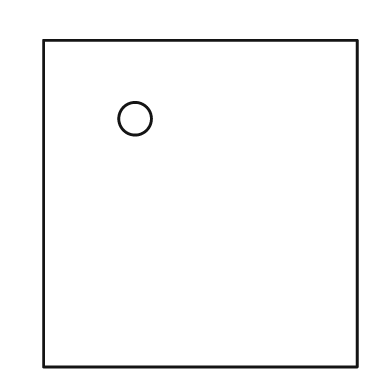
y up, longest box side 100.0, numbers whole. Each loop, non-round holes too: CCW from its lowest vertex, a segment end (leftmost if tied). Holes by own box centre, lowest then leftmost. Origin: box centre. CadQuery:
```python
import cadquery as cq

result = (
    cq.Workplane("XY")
    .moveTo(-48.0, -50.0)
    .lineTo(48.0, -50.0)
    .lineTo(48.0, 50.0)
    .lineTo(-48.0, 50.0)
    .close()
    .moveTo(-20.0, 26.0)
    .circle(5.0)
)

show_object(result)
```